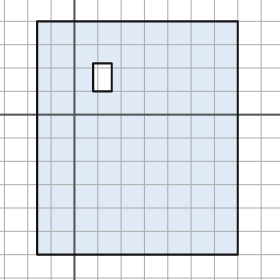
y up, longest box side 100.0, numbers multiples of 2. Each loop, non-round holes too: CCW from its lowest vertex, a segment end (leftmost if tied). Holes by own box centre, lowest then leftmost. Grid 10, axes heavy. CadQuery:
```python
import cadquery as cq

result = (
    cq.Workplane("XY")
    .moveTo(-16.0, -60.0)
    .lineTo(70.0, -60.0)
    .lineTo(70.0, 40.0)
    .lineTo(-16.0, 40.0)
    .close()
    .moveTo(8.0, 10.0)
    .lineTo(16.0, 10.0)
    .lineTo(16.0, 22.0)
    .lineTo(8.0, 22.0)
    .close()
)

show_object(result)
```